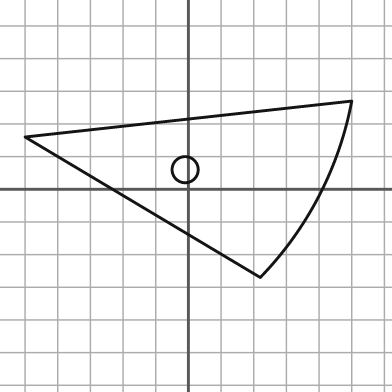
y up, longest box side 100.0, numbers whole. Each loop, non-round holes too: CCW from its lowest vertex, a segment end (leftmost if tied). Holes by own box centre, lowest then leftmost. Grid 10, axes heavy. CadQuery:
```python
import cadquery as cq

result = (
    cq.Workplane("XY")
    .moveTo(22.0, -27.0)
    .threePointArc((40.0, -2.0), (50.0, 27.0))
    .lineTo(-50.0, 16.0)
    .close()
    .moveTo(-1.0, 6.0)
    .circle(4.0)
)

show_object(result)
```